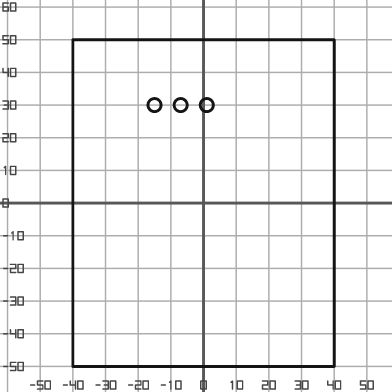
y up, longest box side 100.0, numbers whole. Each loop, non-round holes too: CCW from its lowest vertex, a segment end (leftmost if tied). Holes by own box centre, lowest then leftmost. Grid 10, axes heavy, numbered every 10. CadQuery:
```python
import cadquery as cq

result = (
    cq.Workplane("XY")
    .moveTo(-40.0, -50.0)
    .lineTo(40.0, -50.0)
    .lineTo(40.0, 50.0)
    .lineTo(-40.0, 50.0)
    .close()
    .moveTo(-15.0, 30.0)
    .circle(2.0)
    .moveTo(-7.0, 30.0)
    .circle(2.0)
    .moveTo(1.0, 30.0)
    .circle(2.0)
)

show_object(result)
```